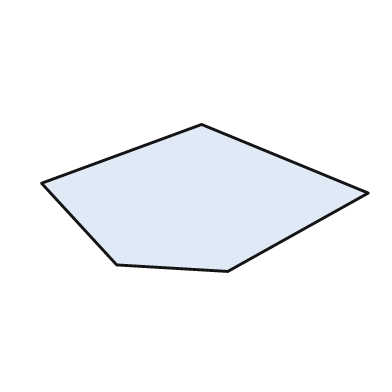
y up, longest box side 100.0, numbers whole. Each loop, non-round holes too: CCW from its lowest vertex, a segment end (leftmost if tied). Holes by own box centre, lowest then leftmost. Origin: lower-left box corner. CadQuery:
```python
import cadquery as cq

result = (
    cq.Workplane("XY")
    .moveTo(57.0, 0.0)
    .lineTo(100.0, 24.0)
    .lineTo(49.0, 45.0)
    .lineTo(0.0, 27.0)
    .lineTo(23.0, 2.0)
    .close()
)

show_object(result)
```